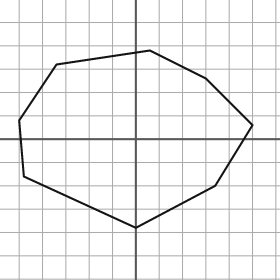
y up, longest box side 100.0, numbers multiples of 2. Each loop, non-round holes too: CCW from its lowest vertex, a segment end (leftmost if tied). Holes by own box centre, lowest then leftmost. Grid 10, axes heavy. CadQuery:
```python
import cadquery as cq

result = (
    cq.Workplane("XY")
    .moveTo(0.0, -38.0)
    .lineTo(34.0, -20.0)
    .lineTo(50.0, 6.0)
    .lineTo(30.0, 26.0)
    .lineTo(6.0, 38.0)
    .lineTo(-34.0, 32.0)
    .lineTo(-50.0, 8.0)
    .lineTo(-48.0, -16.0)
    .close()
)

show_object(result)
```